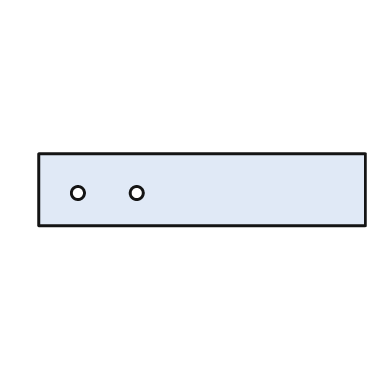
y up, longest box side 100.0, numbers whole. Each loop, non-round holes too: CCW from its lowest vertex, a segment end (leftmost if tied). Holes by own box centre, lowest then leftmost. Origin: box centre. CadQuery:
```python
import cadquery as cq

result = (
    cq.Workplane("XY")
    .moveTo(-50.0, -11.0)
    .lineTo(50.0, -11.0)
    .lineTo(50.0, 11.0)
    .lineTo(-50.0, 11.0)
    .close()
    .moveTo(-38.0, -1.0)
    .circle(2.0)
    .moveTo(-20.0, -1.0)
    .circle(2.0)
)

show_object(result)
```